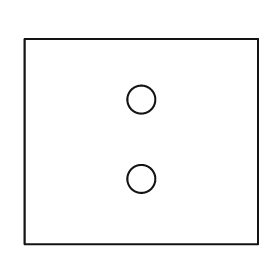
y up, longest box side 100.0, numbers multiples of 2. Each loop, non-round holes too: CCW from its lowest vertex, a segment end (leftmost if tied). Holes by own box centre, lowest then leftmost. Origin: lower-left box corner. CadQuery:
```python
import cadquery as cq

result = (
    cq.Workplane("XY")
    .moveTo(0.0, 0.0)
    .lineTo(100.0, 0.0)
    .lineTo(100.0, 88.0)
    .lineTo(0.0, 88.0)
    .close()
    .moveTo(50.0, 28.0)
    .circle(6.0)
    .moveTo(50.0, 62.0)
    .circle(6.0)
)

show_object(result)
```